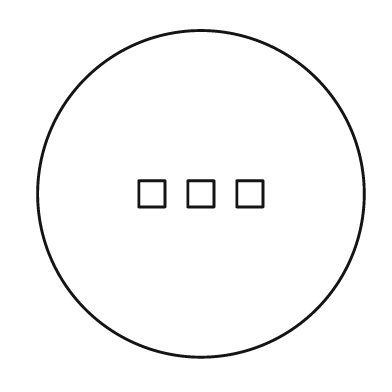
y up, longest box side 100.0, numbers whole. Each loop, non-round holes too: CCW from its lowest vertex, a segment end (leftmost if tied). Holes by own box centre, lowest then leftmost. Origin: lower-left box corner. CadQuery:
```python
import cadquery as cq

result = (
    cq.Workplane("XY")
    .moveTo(50.0, 50.0)
    .circle(50.0)
    .moveTo(31.0, 46.0)
    .lineTo(39.0, 46.0)
    .lineTo(39.0, 54.0)
    .lineTo(31.0, 54.0)
    .close()
    .moveTo(46.0, 46.0)
    .lineTo(54.0, 46.0)
    .lineTo(54.0, 54.0)
    .lineTo(46.0, 54.0)
    .close()
    .moveTo(61.0, 46.0)
    .lineTo(69.0, 46.0)
    .lineTo(69.0, 54.0)
    .lineTo(61.0, 54.0)
    .close()
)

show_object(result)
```